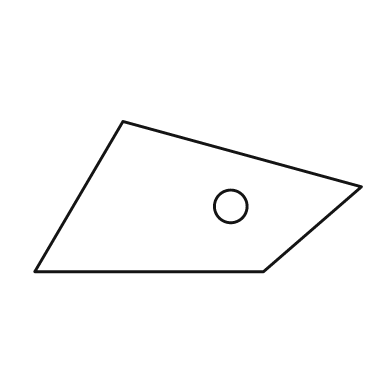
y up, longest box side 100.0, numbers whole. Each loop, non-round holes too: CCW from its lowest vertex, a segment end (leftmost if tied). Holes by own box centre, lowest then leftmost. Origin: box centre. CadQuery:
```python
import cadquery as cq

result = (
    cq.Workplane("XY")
    .moveTo(-50.0, -23.0)
    .lineTo(20.0, -23.0)
    .lineTo(50.0, 3.0)
    .lineTo(-23.0, 23.0)
    .close()
    .moveTo(10.0, -3.0)
    .circle(5.0)
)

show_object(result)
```